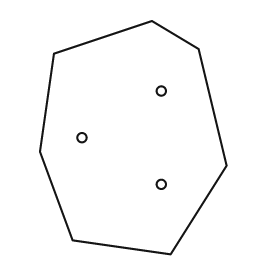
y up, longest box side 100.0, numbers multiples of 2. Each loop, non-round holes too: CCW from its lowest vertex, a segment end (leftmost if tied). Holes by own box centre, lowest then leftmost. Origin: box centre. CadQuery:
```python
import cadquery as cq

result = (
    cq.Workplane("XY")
    .moveTo(16.0, -50.0)
    .lineTo(40.0, -12.0)
    .lineTo(28.0, 38.0)
    .lineTo(8.0, 50.0)
    .lineTo(-34.0, 36.0)
    .lineTo(-40.0, -6.0)
    .lineTo(-26.0, -44.0)
    .close()
    .moveTo(12.0, -20.0)
    .circle(2.0)
    .moveTo(-22.0, 0.0)
    .circle(2.0)
    .moveTo(12.0, 20.0)
    .circle(2.0)
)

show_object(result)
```